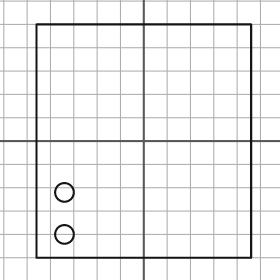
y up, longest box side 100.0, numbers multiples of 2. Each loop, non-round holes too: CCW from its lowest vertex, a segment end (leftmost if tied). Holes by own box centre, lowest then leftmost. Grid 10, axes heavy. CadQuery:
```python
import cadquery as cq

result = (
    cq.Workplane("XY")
    .moveTo(-46.0, -50.0)
    .lineTo(46.0, -50.0)
    .lineTo(46.0, 50.0)
    .lineTo(-46.0, 50.0)
    .close()
    .moveTo(-34.0, -40.0)
    .circle(4.0)
    .moveTo(-34.0, -22.0)
    .circle(4.0)
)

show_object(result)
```